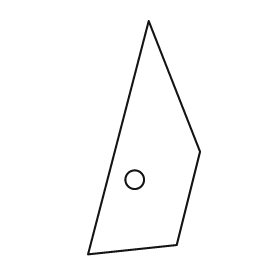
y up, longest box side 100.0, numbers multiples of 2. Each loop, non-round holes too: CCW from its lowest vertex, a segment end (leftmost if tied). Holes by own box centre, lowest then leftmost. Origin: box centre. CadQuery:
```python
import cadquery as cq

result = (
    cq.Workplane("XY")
    .moveTo(-24.0, -50.0)
    .lineTo(14.0, -46.0)
    .lineTo(24.0, -6.0)
    .lineTo(2.0, 50.0)
    .close()
    .moveTo(-4.0, -18.0)
    .circle(4.0)
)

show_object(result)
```